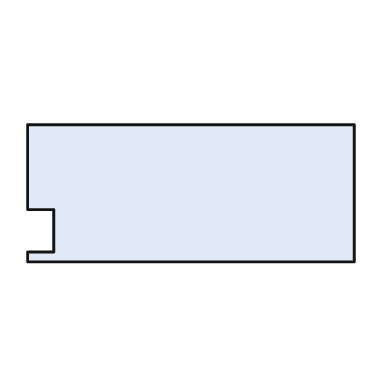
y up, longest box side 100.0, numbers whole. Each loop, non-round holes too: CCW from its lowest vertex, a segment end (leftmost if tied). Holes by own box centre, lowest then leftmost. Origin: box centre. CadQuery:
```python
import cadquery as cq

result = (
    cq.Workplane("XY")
    .moveTo(-50.0, -21.0)
    .lineTo(50.0, -21.0)
    .lineTo(50.0, 21.0)
    .lineTo(-50.0, 21.0)
    .lineTo(-50.0, -5.0)
    .lineTo(-42.0, -5.0)
    .lineTo(-42.0, -18.0)
    .lineTo(-50.0, -18.0)
    .close()
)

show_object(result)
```